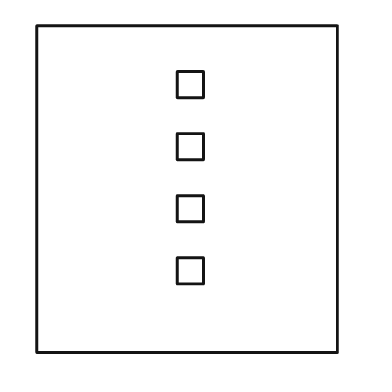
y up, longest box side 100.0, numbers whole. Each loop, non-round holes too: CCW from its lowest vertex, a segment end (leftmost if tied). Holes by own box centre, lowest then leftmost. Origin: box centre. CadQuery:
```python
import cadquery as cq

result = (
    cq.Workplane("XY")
    .moveTo(-46.0, -50.0)
    .lineTo(46.0, -50.0)
    .lineTo(46.0, 50.0)
    .lineTo(-46.0, 50.0)
    .close()
    .moveTo(-3.0, -29.0)
    .lineTo(5.0, -29.0)
    .lineTo(5.0, -21.0)
    .lineTo(-3.0, -21.0)
    .close()
    .moveTo(-3.0, -10.0)
    .lineTo(5.0, -10.0)
    .lineTo(5.0, -2.0)
    .lineTo(-3.0, -2.0)
    .close()
    .moveTo(-3.0, 9.0)
    .lineTo(5.0, 9.0)
    .lineTo(5.0, 17.0)
    .lineTo(-3.0, 17.0)
    .close()
    .moveTo(-3.0, 28.0)
    .lineTo(5.0, 28.0)
    .lineTo(5.0, 36.0)
    .lineTo(-3.0, 36.0)
    .close()
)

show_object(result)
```